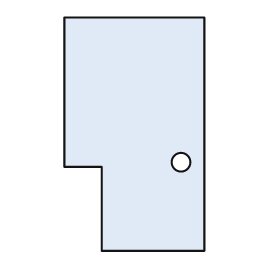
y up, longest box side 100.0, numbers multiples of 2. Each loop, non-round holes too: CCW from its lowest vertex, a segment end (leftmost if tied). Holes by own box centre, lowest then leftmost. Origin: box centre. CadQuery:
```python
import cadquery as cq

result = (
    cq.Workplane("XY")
    .moveTo(-14.0, -50.0)
    .lineTo(30.0, -50.0)
    .lineTo(30.0, 50.0)
    .lineTo(-30.0, 50.0)
    .lineTo(-30.0, -14.0)
    .lineTo(-14.0, -14.0)
    .close()
    .moveTo(20.0, -12.0)
    .circle(4.0)
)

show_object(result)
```